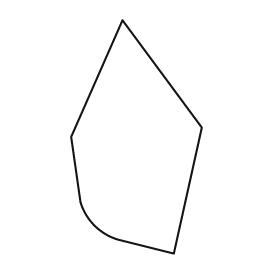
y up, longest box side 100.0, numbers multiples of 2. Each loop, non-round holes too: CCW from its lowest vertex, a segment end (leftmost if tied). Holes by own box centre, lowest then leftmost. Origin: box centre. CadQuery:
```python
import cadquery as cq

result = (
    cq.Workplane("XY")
    .moveTo(16.0, -50.0)
    .lineTo(28.0, 4.0)
    .lineTo(-6.0, 50.0)
    .lineTo(-28.0, 0.0)
    .lineTo(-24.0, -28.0)
    .threePointArc((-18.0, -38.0), (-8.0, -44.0))
    .close()
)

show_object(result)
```